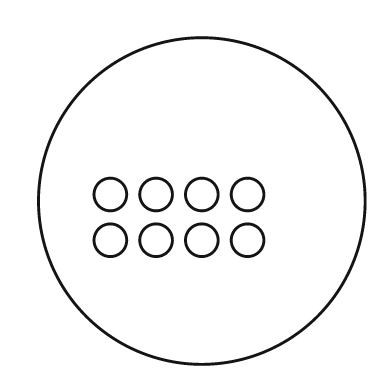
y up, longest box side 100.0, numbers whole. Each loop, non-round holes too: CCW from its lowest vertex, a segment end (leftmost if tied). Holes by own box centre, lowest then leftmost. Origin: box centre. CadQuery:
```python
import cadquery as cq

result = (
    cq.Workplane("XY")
    .moveTo(0.0, 0.0)
    .circle(50.0)
    .moveTo(-28.0, -12.0)
    .circle(5.0)
    .moveTo(-14.0, -12.0)
    .circle(5.0)
    .moveTo(0.0, -12.0)
    .circle(5.0)
    .moveTo(14.0, -12.0)
    .circle(5.0)
    .moveTo(-28.0, 2.0)
    .circle(5.0)
    .moveTo(-14.0, 2.0)
    .circle(5.0)
    .moveTo(0.0, 2.0)
    .circle(5.0)
    .moveTo(14.0, 2.0)
    .circle(5.0)
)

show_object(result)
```